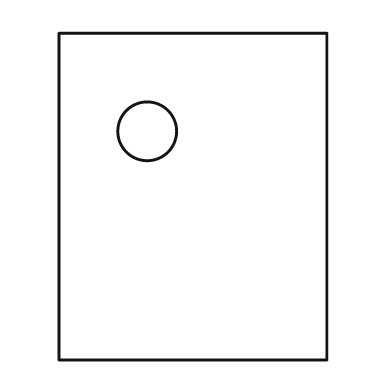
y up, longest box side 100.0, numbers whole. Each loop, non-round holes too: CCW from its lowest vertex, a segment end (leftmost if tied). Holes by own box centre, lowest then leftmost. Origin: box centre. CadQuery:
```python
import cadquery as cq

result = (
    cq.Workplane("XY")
    .moveTo(-41.0, -50.0)
    .lineTo(41.0, -50.0)
    .lineTo(41.0, 50.0)
    .lineTo(-41.0, 50.0)
    .close()
    .moveTo(-14.0, 20.0)
    .circle(9.0)
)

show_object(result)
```